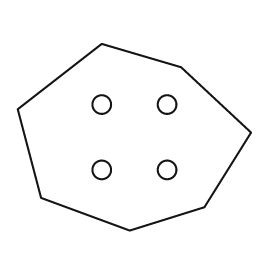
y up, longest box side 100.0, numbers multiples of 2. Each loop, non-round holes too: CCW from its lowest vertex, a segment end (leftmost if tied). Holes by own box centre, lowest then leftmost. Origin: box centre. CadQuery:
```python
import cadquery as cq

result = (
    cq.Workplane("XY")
    .moveTo(-2.0, -40.0)
    .lineTo(30.0, -30.0)
    .lineTo(50.0, 2.0)
    .lineTo(20.0, 30.0)
    .lineTo(-14.0, 40.0)
    .lineTo(-50.0, 12.0)
    .lineTo(-40.0, -26.0)
    .close()
    .moveTo(-14.0, -14.0)
    .circle(4.0)
    .moveTo(14.0, -14.0)
    .circle(4.0)
    .moveTo(-14.0, 14.0)
    .circle(4.0)
    .moveTo(14.0, 14.0)
    .circle(4.0)
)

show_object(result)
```